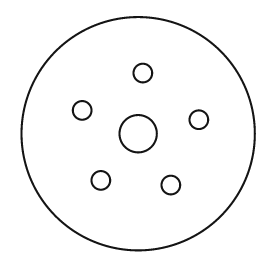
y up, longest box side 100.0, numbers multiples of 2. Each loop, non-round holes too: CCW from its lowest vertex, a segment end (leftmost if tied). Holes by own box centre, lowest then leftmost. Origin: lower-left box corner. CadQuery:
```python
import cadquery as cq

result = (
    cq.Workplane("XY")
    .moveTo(50.0, 50.0)
    .circle(50.0)
    .moveTo(64.0, 28.0)
    .circle(4.0)
    .moveTo(34.0, 30.0)
    .circle(4.0)
    .moveTo(50.0, 50.0)
    .circle(8.0)
    .moveTo(76.0, 56.0)
    .circle(4.0)
    .moveTo(26.0, 60.0)
    .circle(4.0)
    .moveTo(52.0, 76.0)
    .circle(4.0)
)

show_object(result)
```